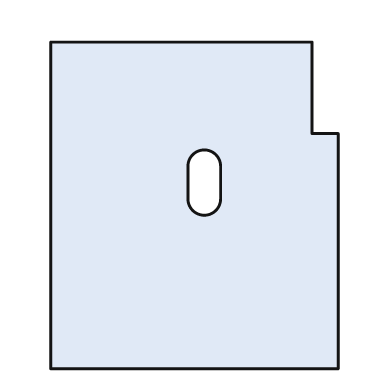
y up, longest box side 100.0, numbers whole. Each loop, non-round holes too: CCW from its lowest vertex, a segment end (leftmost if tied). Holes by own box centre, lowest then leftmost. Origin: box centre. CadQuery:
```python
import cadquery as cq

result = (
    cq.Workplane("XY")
    .moveTo(-44.0, -50.0)
    .lineTo(44.0, -50.0)
    .lineTo(44.0, 22.0)
    .lineTo(36.0, 22.0)
    .lineTo(36.0, 50.0)
    .lineTo(-44.0, 50.0)
    .close()
    .moveTo(-2.0, 2.0)
    .threePointArc((3.0, -3.0), (8.0, 2.0))
    .lineTo(8.0, 12.0)
    .threePointArc((3.0, 17.0), (-2.0, 12.0))
    .close()
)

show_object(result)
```